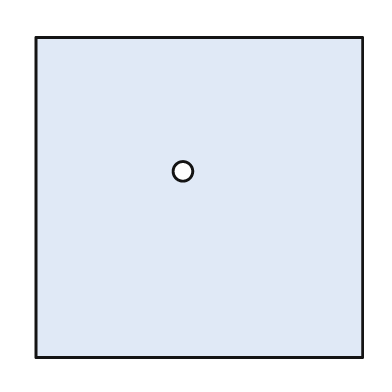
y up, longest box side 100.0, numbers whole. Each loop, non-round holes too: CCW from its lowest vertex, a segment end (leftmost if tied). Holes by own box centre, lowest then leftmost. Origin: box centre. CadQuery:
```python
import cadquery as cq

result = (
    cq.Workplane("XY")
    .moveTo(-50.0, -49.0)
    .lineTo(50.0, -49.0)
    .lineTo(50.0, 49.0)
    .lineTo(-50.0, 49.0)
    .close()
    .moveTo(-5.0, 8.0)
    .circle(3.0)
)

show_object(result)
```